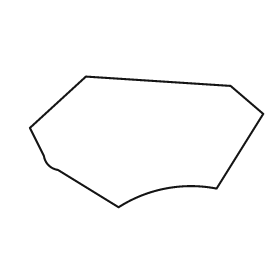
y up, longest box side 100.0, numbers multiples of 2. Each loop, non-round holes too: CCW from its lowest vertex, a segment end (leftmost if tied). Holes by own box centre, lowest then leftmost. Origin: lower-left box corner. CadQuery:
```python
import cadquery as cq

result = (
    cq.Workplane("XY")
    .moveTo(38.0, 0.0)
    .threePointArc((58.0, 8.0), (80.0, 8.0))
    .lineTo(100.0, 40.0)
    .lineTo(86.0, 52.0)
    .lineTo(24.0, 56.0)
    .lineTo(0.0, 34.0)
    .lineTo(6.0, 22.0)
    .threePointArc((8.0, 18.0), (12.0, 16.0))
    .close()
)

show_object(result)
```